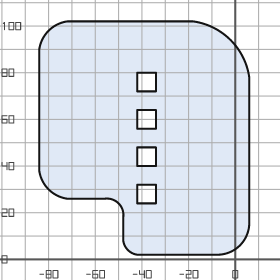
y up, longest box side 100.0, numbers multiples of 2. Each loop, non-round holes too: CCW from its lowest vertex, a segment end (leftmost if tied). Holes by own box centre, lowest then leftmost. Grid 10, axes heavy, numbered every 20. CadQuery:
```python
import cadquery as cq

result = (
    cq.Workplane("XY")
    .moveTo(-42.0, 2.0)
    .lineTo(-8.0, 2.0)
    .threePointArc((2.0, 6.0), (6.0, 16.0))
    .lineTo(6.0, 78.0)
    .threePointArc((-2.0, 94.0), (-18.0, 102.0))
    .lineTo(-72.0, 102.0)
    .threePointArc((-80.0, 98.0), (-84.0, 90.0))
    .lineTo(-84.0, 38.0)
    .threePointArc((-80.0, 30.0), (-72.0, 26.0))
    .lineTo(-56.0, 26.0)
    .threePointArc((-50.0, 24.0), (-48.0, 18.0))
    .lineTo(-48.0, 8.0)
    .threePointArc((-46.0, 4.0), (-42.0, 2.0))
    .close()
    .moveTo(-42.0, 24.0)
    .lineTo(-34.0, 24.0)
    .lineTo(-34.0, 32.0)
    .lineTo(-42.0, 32.0)
    .close()
    .moveTo(-42.0, 40.0)
    .lineTo(-34.0, 40.0)
    .lineTo(-34.0, 48.0)
    .lineTo(-42.0, 48.0)
    .close()
    .moveTo(-42.0, 56.0)
    .lineTo(-34.0, 56.0)
    .lineTo(-34.0, 64.0)
    .lineTo(-42.0, 64.0)
    .close()
    .moveTo(-42.0, 72.0)
    .lineTo(-34.0, 72.0)
    .lineTo(-34.0, 80.0)
    .lineTo(-42.0, 80.0)
    .close()
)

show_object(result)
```